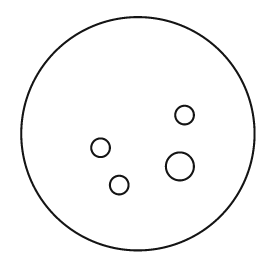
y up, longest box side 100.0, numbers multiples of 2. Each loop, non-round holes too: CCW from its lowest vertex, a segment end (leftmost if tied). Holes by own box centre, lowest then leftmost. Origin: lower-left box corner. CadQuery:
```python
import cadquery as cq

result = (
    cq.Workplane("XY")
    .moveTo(50.0, 50.0)
    .circle(50.0)
    .moveTo(42.0, 28.0)
    .circle(4.0)
    .moveTo(68.0, 36.0)
    .circle(6.0)
    .moveTo(34.0, 44.0)
    .circle(4.0)
    .moveTo(70.0, 58.0)
    .circle(4.0)
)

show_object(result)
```